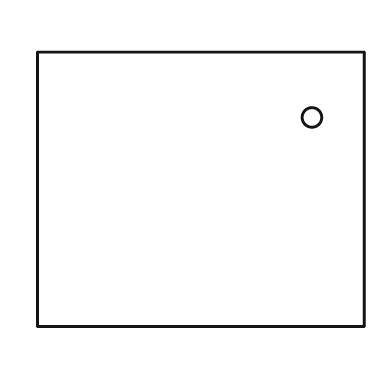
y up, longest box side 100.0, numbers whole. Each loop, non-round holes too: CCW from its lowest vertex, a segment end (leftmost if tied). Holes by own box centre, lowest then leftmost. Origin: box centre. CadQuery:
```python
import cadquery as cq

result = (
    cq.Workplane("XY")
    .moveTo(-50.0, -42.0)
    .lineTo(50.0, -42.0)
    .lineTo(50.0, 42.0)
    .lineTo(-50.0, 42.0)
    .close()
    .moveTo(34.0, 22.0)
    .circle(3.0)
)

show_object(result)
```